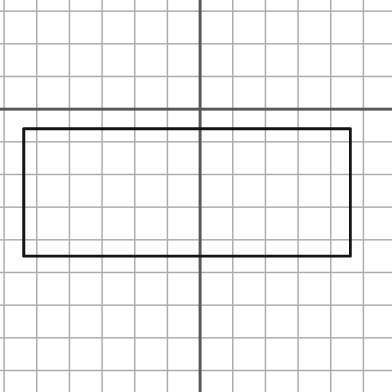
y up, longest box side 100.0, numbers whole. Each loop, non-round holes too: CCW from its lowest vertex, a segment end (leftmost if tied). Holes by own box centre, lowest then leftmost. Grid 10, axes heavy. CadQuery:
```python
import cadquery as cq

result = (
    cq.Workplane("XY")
    .moveTo(-54.0, -45.0)
    .lineTo(46.0, -45.0)
    .lineTo(46.0, -6.0)
    .lineTo(-54.0, -6.0)
    .close()
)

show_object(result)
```